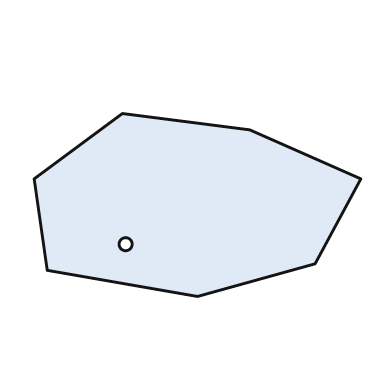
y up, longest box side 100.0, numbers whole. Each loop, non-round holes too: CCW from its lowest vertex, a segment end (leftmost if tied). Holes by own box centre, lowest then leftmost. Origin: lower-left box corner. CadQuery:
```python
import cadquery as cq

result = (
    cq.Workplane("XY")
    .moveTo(50.0, 0.0)
    .lineTo(86.0, 10.0)
    .lineTo(100.0, 36.0)
    .lineTo(66.0, 51.0)
    .lineTo(27.0, 56.0)
    .lineTo(0.0, 36.0)
    .lineTo(4.0, 8.0)
    .close()
    .moveTo(28.0, 16.0)
    .circle(2.0)
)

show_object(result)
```